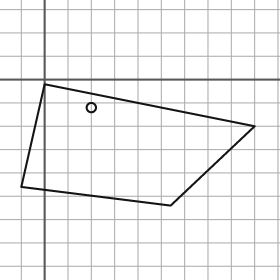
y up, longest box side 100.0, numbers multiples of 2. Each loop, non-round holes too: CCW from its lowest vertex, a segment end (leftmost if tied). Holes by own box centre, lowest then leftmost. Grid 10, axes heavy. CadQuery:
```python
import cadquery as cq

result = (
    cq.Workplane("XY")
    .moveTo(54.0, -54.0)
    .lineTo(90.0, -20.0)
    .lineTo(0.0, -2.0)
    .lineTo(-10.0, -46.0)
    .close()
    .moveTo(20.0, -12.0)
    .circle(2.0)
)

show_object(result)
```